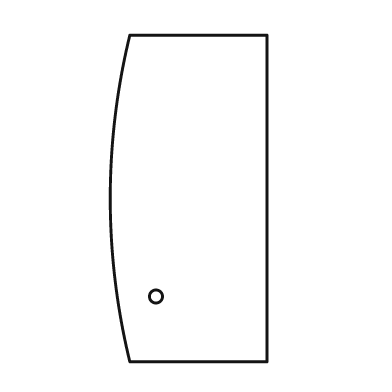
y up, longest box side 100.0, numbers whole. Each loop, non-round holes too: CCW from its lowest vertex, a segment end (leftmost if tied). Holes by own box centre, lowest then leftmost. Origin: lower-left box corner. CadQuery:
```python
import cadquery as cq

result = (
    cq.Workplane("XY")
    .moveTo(6.0, 0.0)
    .lineTo(48.0, 0.0)
    .lineTo(48.0, 100.0)
    .lineTo(6.0, 100.0)
    .threePointArc((0.0, 50.0), (6.0, 0.0))
    .close()
    .moveTo(14.0, 20.0)
    .circle(2.0)
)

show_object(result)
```